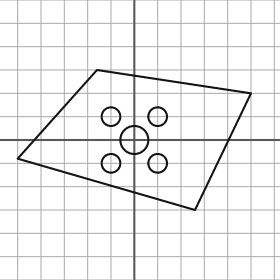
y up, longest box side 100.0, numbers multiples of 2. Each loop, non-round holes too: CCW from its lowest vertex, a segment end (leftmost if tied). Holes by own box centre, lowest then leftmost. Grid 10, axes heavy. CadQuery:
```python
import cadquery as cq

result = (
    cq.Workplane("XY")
    .moveTo(26.0, -30.0)
    .lineTo(50.0, 20.0)
    .lineTo(-16.0, 30.0)
    .lineTo(-50.0, -8.0)
    .close()
    .moveTo(-10.0, -10.0)
    .circle(4.0)
    .moveTo(10.0, -10.0)
    .circle(4.0)
    .moveTo(0.0, 0.0)
    .circle(6.0)
    .moveTo(-10.0, 10.0)
    .circle(4.0)
    .moveTo(10.0, 10.0)
    .circle(4.0)
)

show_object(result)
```